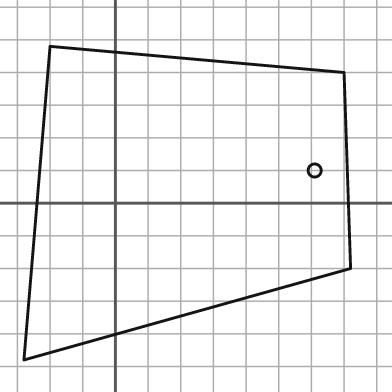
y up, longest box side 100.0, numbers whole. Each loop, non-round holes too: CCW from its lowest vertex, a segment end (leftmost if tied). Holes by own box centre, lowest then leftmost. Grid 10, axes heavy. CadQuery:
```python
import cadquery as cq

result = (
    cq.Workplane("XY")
    .moveTo(-28.0, -48.0)
    .lineTo(72.0, -20.0)
    .lineTo(70.0, 40.0)
    .lineTo(-20.0, 48.0)
    .close()
    .moveTo(61.0, 10.0)
    .circle(2.0)
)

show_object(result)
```